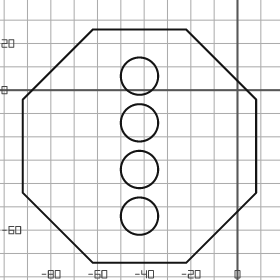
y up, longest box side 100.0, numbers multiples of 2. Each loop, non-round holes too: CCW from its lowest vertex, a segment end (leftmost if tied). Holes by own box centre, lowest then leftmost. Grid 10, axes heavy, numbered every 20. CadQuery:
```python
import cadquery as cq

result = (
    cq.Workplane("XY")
    .moveTo(-62.0, -74.0)
    .lineTo(-22.0, -74.0)
    .lineTo(8.0, -44.0)
    .lineTo(8.0, -4.0)
    .lineTo(-22.0, 26.0)
    .lineTo(-62.0, 26.0)
    .lineTo(-92.0, -4.0)
    .lineTo(-92.0, -44.0)
    .close()
    .moveTo(-42.0, -54.0)
    .circle(8.0)
    .moveTo(-42.0, -34.0)
    .circle(8.0)
    .moveTo(-42.0, -14.0)
    .circle(8.0)
    .moveTo(-42.0, 6.0)
    .circle(8.0)
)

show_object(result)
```